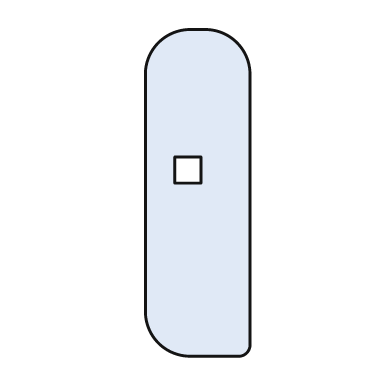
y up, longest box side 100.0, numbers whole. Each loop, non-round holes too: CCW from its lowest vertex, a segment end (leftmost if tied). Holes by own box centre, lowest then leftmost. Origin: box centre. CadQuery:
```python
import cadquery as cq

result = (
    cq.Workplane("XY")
    .moveTo(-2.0, -50.0)
    .lineTo(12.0, -50.0)
    .threePointArc((15.0, -49.0), (16.0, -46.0))
    .lineTo(16.0, 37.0)
    .threePointArc((12.0, 46.0), (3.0, 50.0))
    .lineTo(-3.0, 50.0)
    .threePointArc((-12.0, 46.0), (-16.0, 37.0))
    .lineTo(-16.0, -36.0)
    .threePointArc((-12.0, -46.0), (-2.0, -50.0))
    .close()
    .moveTo(-7.0, 3.0)
    .lineTo(1.0, 3.0)
    .lineTo(1.0, 11.0)
    .lineTo(-7.0, 11.0)
    .close()
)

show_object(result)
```